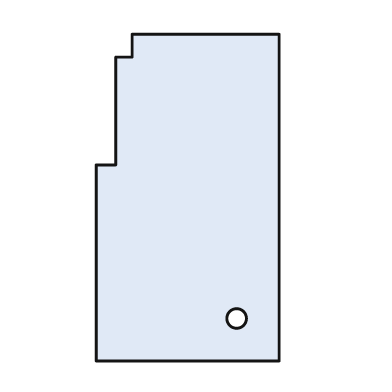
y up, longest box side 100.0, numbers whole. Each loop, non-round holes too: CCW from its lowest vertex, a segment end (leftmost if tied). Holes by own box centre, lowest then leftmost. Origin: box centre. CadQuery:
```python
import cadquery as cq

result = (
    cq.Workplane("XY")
    .moveTo(-28.0, -50.0)
    .lineTo(28.0, -50.0)
    .lineTo(28.0, 50.0)
    .lineTo(-17.0, 50.0)
    .lineTo(-17.0, 43.0)
    .lineTo(-22.0, 43.0)
    .lineTo(-22.0, 10.0)
    .lineTo(-28.0, 10.0)
    .close()
    .moveTo(15.0, -37.0)
    .circle(3.0)
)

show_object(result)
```